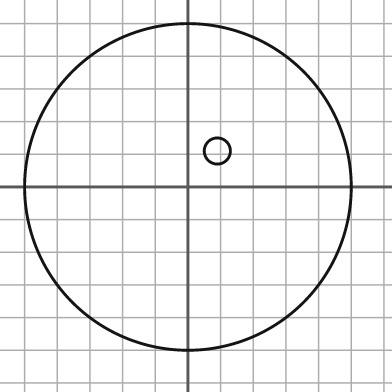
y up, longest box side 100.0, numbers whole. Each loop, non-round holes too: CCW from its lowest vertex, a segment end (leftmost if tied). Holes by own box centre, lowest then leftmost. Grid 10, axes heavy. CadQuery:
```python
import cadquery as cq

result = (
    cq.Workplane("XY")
    .moveTo(0.0, 0.0)
    .circle(50.0)
    .moveTo(9.0, 11.0)
    .circle(4.0)
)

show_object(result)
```